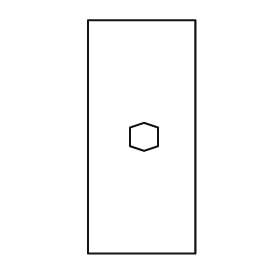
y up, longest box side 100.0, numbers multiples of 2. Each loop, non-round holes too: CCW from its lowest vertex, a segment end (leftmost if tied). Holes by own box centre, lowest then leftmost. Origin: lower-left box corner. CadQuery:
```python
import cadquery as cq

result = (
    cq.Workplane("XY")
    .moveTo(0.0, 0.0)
    .lineTo(46.0, 0.0)
    .lineTo(46.0, 100.0)
    .lineTo(0.0, 100.0)
    .close()
    .moveTo(24.0, 44.0)
    .lineTo(30.0, 46.0)
    .lineTo(30.0, 54.0)
    .lineTo(24.0, 56.0)
    .lineTo(18.0, 54.0)
    .lineTo(18.0, 46.0)
    .close()
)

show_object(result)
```